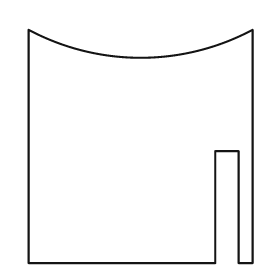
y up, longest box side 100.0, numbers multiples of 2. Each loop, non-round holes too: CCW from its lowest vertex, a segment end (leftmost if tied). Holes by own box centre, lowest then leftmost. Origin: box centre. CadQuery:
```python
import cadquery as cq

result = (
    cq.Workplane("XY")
    .moveTo(-48.0, -50.0)
    .lineTo(32.0, -50.0)
    .lineTo(32.0, -2.0)
    .lineTo(42.0, -2.0)
    .lineTo(42.0, -50.0)
    .lineTo(48.0, -50.0)
    .lineTo(48.0, 50.0)
    .threePointArc((0.0, 38.0), (-48.0, 50.0))
    .close()
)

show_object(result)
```